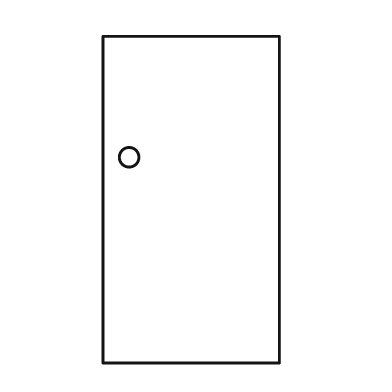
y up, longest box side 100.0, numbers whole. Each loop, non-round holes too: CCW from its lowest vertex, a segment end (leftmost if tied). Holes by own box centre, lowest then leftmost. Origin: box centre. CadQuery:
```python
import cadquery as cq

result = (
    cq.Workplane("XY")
    .moveTo(-27.0, -50.0)
    .lineTo(27.0, -50.0)
    .lineTo(27.0, 50.0)
    .lineTo(-27.0, 50.0)
    .close()
    .moveTo(-19.0, 13.0)
    .circle(3.0)
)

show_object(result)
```